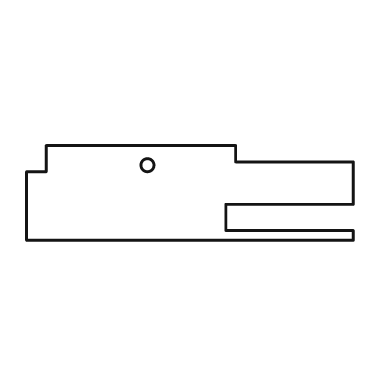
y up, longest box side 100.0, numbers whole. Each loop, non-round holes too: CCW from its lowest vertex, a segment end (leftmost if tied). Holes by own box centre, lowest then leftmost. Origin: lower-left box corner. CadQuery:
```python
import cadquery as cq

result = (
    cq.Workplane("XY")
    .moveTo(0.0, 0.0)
    .lineTo(100.0, 0.0)
    .lineTo(100.0, 3.0)
    .lineTo(61.0, 3.0)
    .lineTo(61.0, 11.0)
    .lineTo(100.0, 11.0)
    .lineTo(100.0, 24.0)
    .lineTo(64.0, 24.0)
    .lineTo(64.0, 29.0)
    .lineTo(6.0, 29.0)
    .lineTo(6.0, 21.0)
    .lineTo(0.0, 21.0)
    .close()
    .moveTo(37.0, 23.0)
    .circle(2.0)
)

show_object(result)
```